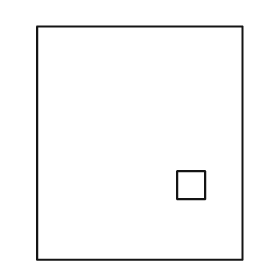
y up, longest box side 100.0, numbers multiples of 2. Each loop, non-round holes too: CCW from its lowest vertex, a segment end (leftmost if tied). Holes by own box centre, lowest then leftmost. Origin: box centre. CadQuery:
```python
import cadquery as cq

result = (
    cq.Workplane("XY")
    .moveTo(-44.0, -50.0)
    .lineTo(44.0, -50.0)
    .lineTo(44.0, 50.0)
    .lineTo(-44.0, 50.0)
    .close()
    .moveTo(16.0, -24.0)
    .lineTo(28.0, -24.0)
    .lineTo(28.0, -12.0)
    .lineTo(16.0, -12.0)
    .close()
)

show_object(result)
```